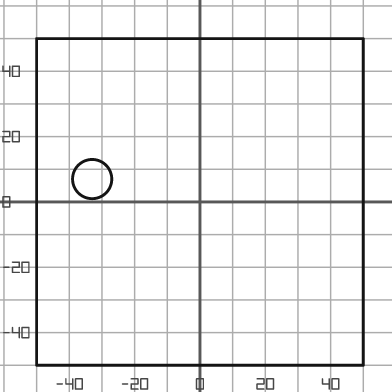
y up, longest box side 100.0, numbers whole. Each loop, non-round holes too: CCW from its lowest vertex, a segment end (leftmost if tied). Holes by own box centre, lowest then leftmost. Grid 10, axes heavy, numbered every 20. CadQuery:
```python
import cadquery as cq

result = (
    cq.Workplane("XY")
    .moveTo(-50.0, -50.0)
    .lineTo(50.0, -50.0)
    .lineTo(50.0, 50.0)
    .lineTo(-50.0, 50.0)
    .close()
    .moveTo(-33.0, 7.0)
    .circle(6.0)
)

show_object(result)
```